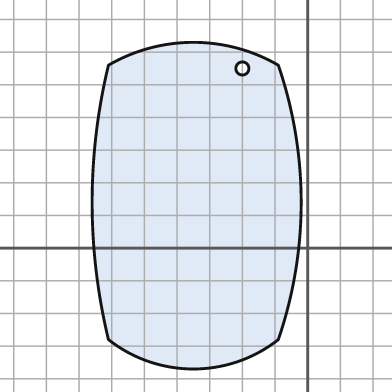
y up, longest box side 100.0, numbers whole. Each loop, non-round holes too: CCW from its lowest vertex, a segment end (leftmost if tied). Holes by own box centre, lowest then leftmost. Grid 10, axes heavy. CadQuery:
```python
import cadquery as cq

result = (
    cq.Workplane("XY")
    .moveTo(-61.0, -28.0)
    .threePointArc((-35.0, -37.0), (-9.0, -28.0))
    .threePointArc((-2.0, 14.0), (-9.0, 56.0))
    .threePointArc((-35.0, 63.0), (-61.0, 56.0))
    .threePointArc((-66.0, 14.0), (-61.0, -28.0))
    .close()
    .moveTo(-20.0, 55.0)
    .circle(2.0)
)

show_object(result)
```